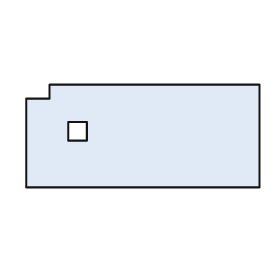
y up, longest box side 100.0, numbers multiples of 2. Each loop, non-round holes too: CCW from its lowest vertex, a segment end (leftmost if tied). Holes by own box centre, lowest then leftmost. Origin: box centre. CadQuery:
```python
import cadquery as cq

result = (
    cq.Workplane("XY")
    .moveTo(-50.0, -22.0)
    .lineTo(50.0, -22.0)
    .lineTo(50.0, 22.0)
    .lineTo(-40.0, 22.0)
    .lineTo(-40.0, 16.0)
    .lineTo(-50.0, 16.0)
    .close()
    .moveTo(-32.0, -2.0)
    .lineTo(-24.0, -2.0)
    .lineTo(-24.0, 6.0)
    .lineTo(-32.0, 6.0)
    .close()
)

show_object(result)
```